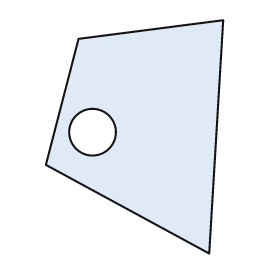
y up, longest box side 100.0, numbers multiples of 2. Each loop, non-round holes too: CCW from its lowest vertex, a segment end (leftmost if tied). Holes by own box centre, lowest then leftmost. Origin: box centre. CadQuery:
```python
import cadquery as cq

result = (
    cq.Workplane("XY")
    .moveTo(32.0, -50.0)
    .lineTo(38.0, 50.0)
    .lineTo(-24.0, 42.0)
    .lineTo(-38.0, -12.0)
    .close()
    .moveTo(-18.0, 2.0)
    .circle(10.0)
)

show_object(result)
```